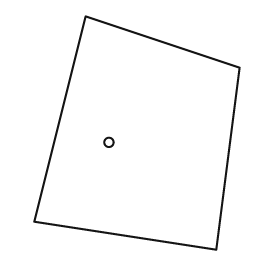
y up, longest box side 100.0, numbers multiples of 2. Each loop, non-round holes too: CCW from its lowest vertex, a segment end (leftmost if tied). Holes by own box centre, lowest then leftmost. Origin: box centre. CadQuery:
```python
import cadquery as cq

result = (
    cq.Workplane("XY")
    .moveTo(34.0, -50.0)
    .lineTo(44.0, 28.0)
    .lineTo(-22.0, 50.0)
    .lineTo(-44.0, -38.0)
    .close()
    .moveTo(-12.0, -4.0)
    .circle(2.0)
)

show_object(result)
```